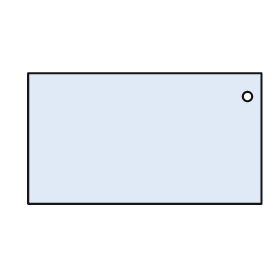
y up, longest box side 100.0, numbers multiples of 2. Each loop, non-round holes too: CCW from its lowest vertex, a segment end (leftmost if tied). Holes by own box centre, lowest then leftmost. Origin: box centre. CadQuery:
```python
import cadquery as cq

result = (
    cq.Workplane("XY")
    .moveTo(-50.0, -28.0)
    .lineTo(50.0, -28.0)
    .lineTo(50.0, 28.0)
    .lineTo(-50.0, 28.0)
    .close()
    .moveTo(44.0, 18.0)
    .circle(2.0)
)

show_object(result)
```